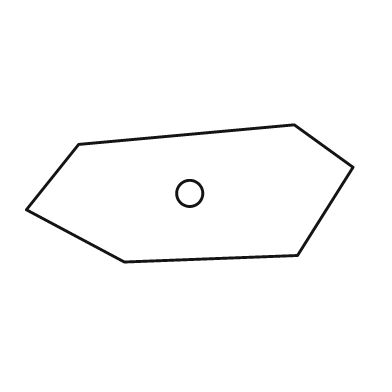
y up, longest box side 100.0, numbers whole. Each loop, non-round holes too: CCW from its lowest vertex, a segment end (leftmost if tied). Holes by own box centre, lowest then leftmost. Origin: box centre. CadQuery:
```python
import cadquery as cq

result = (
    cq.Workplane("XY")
    .moveTo(-20.0, -21.0)
    .lineTo(33.0, -19.0)
    .lineTo(50.0, 8.0)
    .lineTo(32.0, 21.0)
    .lineTo(-34.0, 15.0)
    .lineTo(-50.0, -5.0)
    .close()
    .moveTo(0.0, 0.0)
    .circle(4.0)
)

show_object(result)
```